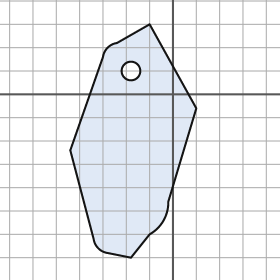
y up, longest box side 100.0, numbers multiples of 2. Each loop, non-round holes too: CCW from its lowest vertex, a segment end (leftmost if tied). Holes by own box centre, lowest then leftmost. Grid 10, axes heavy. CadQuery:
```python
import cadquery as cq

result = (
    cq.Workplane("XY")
    .moveTo(-18.0, -70.0)
    .lineTo(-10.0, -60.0)
    .threePointArc((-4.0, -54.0), (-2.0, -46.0))
    .lineTo(10.0, -6.0)
    .lineTo(-10.0, 30.0)
    .lineTo(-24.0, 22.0)
    .threePointArc((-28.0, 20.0), (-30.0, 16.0))
    .lineTo(-44.0, -24.0)
    .lineTo(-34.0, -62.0)
    .threePointArc((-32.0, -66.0), (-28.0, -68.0))
    .close()
    .moveTo(-18.0, 10.0)
    .circle(4.0)
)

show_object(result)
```